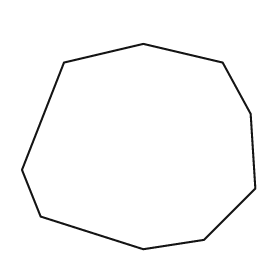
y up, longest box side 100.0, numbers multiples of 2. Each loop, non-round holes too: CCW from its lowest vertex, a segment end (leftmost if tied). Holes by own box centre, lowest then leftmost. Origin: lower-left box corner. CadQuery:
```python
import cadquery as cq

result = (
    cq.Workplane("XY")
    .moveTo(52.0, 0.0)
    .lineTo(78.0, 4.0)
    .lineTo(100.0, 26.0)
    .lineTo(98.0, 58.0)
    .lineTo(86.0, 80.0)
    .lineTo(52.0, 88.0)
    .lineTo(18.0, 80.0)
    .lineTo(0.0, 34.0)
    .lineTo(8.0, 14.0)
    .close()
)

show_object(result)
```